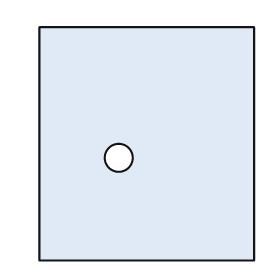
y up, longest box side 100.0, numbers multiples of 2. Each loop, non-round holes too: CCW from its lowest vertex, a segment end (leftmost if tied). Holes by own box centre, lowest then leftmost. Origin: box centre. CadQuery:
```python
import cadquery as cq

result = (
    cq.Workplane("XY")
    .moveTo(-46.0, -50.0)
    .lineTo(46.0, -50.0)
    .lineTo(46.0, 50.0)
    .lineTo(-46.0, 50.0)
    .close()
    .moveTo(-12.0, -6.0)
    .circle(6.0)
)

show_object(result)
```